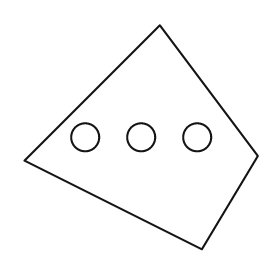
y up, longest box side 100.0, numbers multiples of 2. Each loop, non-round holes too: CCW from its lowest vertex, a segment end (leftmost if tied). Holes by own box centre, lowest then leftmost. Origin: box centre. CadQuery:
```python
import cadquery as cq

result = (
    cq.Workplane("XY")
    .moveTo(26.0, -48.0)
    .lineTo(50.0, -8.0)
    .lineTo(8.0, 48.0)
    .lineTo(-50.0, -10.0)
    .close()
    .moveTo(-24.0, 0.0)
    .circle(6.0)
    .moveTo(0.0, 0.0)
    .circle(6.0)
    .moveTo(24.0, 0.0)
    .circle(6.0)
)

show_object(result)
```